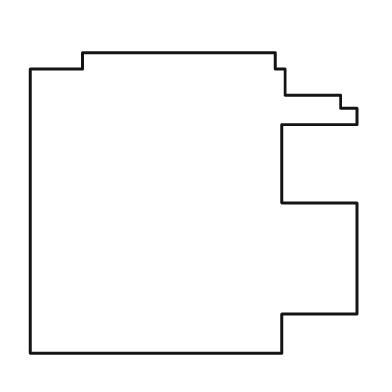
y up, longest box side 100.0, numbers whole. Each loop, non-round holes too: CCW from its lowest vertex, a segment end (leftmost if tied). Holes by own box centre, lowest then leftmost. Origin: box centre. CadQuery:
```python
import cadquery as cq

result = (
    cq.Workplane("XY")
    .moveTo(-50.0, -46.0)
    .lineTo(27.0, -46.0)
    .lineTo(27.0, -34.0)
    .lineTo(50.0, -34.0)
    .lineTo(50.0, 0.0)
    .lineTo(27.0, 0.0)
    .lineTo(27.0, 24.0)
    .lineTo(50.0, 24.0)
    .lineTo(50.0, 29.0)
    .lineTo(45.0, 29.0)
    .lineTo(45.0, 33.0)
    .lineTo(28.0, 33.0)
    .lineTo(28.0, 41.0)
    .lineTo(25.0, 41.0)
    .lineTo(25.0, 46.0)
    .lineTo(-34.0, 46.0)
    .lineTo(-34.0, 41.0)
    .lineTo(-50.0, 41.0)
    .close()
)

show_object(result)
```